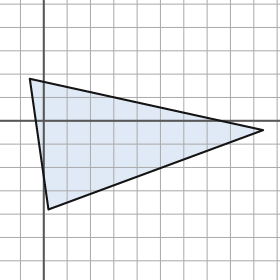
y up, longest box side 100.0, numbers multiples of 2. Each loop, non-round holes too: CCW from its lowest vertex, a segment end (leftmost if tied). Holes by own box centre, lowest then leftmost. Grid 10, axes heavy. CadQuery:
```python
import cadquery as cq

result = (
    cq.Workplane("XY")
    .moveTo(2.0, -38.0)
    .lineTo(94.0, -4.0)
    .lineTo(-6.0, 18.0)
    .close()
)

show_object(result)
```